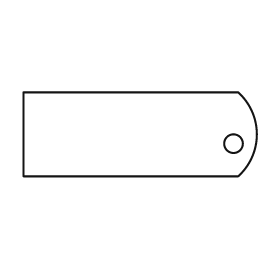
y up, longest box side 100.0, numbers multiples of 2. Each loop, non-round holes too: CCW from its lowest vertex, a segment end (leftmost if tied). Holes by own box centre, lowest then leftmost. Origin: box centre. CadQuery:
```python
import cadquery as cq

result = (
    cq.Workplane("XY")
    .moveTo(-50.0, -18.0)
    .lineTo(42.0, -18.0)
    .threePointArc((50.0, 0.0), (42.0, 18.0))
    .lineTo(-50.0, 18.0)
    .close()
    .moveTo(40.0, -4.0)
    .circle(4.0)
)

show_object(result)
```